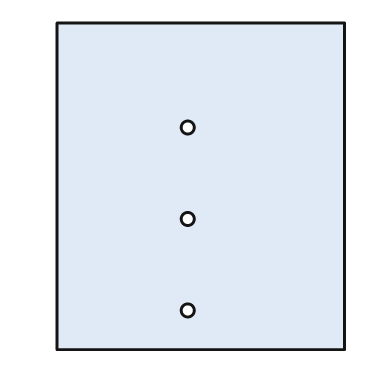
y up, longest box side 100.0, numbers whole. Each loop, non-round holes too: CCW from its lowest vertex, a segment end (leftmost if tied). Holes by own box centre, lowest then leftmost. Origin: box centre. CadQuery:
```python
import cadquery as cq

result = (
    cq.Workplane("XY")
    .moveTo(-44.0, -50.0)
    .lineTo(44.0, -50.0)
    .lineTo(44.0, 50.0)
    .lineTo(-44.0, 50.0)
    .close()
    .moveTo(-4.0, -38.0)
    .circle(2.0)
    .moveTo(-4.0, -10.0)
    .circle(2.0)
    .moveTo(-4.0, 18.0)
    .circle(2.0)
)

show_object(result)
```